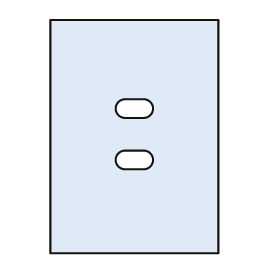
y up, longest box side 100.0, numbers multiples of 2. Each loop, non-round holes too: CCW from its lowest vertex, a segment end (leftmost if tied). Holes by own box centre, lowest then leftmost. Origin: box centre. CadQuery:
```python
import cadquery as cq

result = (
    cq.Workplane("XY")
    .moveTo(-36.0, -50.0)
    .lineTo(36.0, -50.0)
    .lineTo(36.0, 50.0)
    .lineTo(-36.0, 50.0)
    .close()
    .moveTo(-4.0, -14.0)
    .lineTo(4.0, -14.0)
    .threePointArc((8.0, -10.0), (4.0, -6.0))
    .lineTo(-4.0, -6.0)
    .threePointArc((-8.0, -10.0), (-4.0, -14.0))
    .close()
    .moveTo(-4.0, 8.0)
    .lineTo(4.0, 8.0)
    .threePointArc((8.0, 12.0), (4.0, 16.0))
    .lineTo(-4.0, 16.0)
    .threePointArc((-8.0, 12.0), (-4.0, 8.0))
    .close()
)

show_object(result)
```